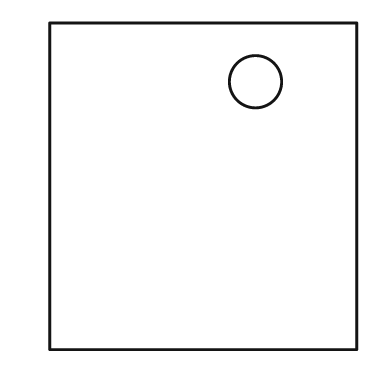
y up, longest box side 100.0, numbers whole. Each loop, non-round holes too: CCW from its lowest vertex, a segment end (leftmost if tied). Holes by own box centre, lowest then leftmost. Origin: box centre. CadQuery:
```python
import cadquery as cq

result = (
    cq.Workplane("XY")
    .moveTo(-47.0, -50.0)
    .lineTo(47.0, -50.0)
    .lineTo(47.0, 50.0)
    .lineTo(-47.0, 50.0)
    .close()
    .moveTo(16.0, 32.0)
    .circle(8.0)
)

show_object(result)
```